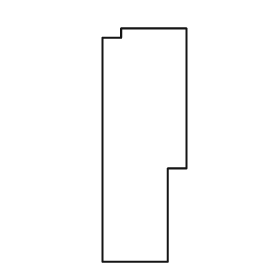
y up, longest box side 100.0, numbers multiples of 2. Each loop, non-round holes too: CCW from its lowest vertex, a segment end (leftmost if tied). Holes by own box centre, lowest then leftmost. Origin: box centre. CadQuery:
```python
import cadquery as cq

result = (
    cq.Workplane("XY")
    .moveTo(-18.0, -50.0)
    .lineTo(10.0, -50.0)
    .lineTo(10.0, -10.0)
    .lineTo(18.0, -10.0)
    .lineTo(18.0, 50.0)
    .lineTo(-10.0, 50.0)
    .lineTo(-10.0, 46.0)
    .lineTo(-18.0, 46.0)
    .close()
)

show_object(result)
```